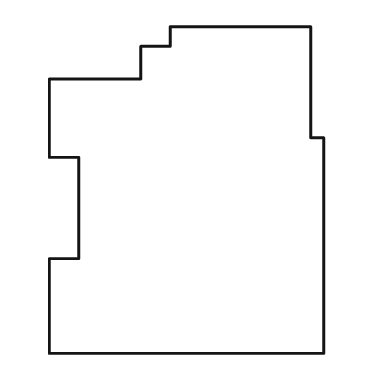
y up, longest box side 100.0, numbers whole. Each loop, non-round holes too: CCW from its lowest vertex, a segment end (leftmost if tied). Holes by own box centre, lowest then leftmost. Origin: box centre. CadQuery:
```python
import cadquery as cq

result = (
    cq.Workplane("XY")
    .moveTo(-42.0, -50.0)
    .lineTo(42.0, -50.0)
    .lineTo(42.0, 16.0)
    .lineTo(38.0, 16.0)
    .lineTo(38.0, 50.0)
    .lineTo(-5.0, 50.0)
    .lineTo(-5.0, 44.0)
    .lineTo(-14.0, 44.0)
    .lineTo(-14.0, 34.0)
    .lineTo(-42.0, 34.0)
    .lineTo(-42.0, 10.0)
    .lineTo(-33.0, 10.0)
    .lineTo(-33.0, -21.0)
    .lineTo(-42.0, -21.0)
    .close()
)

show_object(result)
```